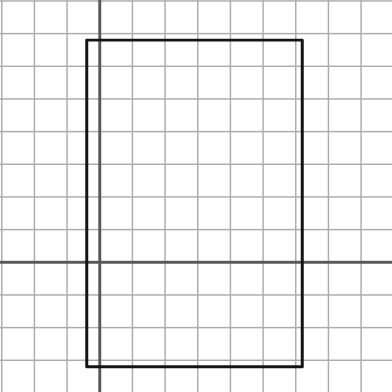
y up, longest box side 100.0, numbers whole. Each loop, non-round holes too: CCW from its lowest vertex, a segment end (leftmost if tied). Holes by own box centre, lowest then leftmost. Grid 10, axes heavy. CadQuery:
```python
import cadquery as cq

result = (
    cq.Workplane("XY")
    .moveTo(-4.0, -32.0)
    .lineTo(62.0, -32.0)
    .lineTo(62.0, 68.0)
    .lineTo(-4.0, 68.0)
    .close()
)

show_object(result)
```